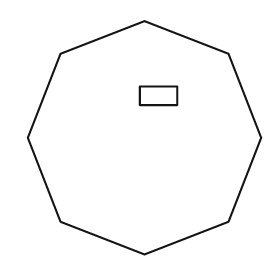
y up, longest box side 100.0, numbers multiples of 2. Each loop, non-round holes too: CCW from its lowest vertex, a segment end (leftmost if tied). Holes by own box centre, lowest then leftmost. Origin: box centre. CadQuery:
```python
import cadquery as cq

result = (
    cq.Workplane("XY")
    .moveTo(0.0, -50.0)
    .lineTo(36.0, -36.0)
    .lineTo(50.0, 0.0)
    .lineTo(36.0, 36.0)
    .lineTo(0.0, 50.0)
    .lineTo(-36.0, 36.0)
    .lineTo(-50.0, 0.0)
    .lineTo(-36.0, -36.0)
    .close()
    .moveTo(-2.0, 14.0)
    .lineTo(14.0, 14.0)
    .lineTo(14.0, 22.0)
    .lineTo(-2.0, 22.0)
    .close()
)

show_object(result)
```